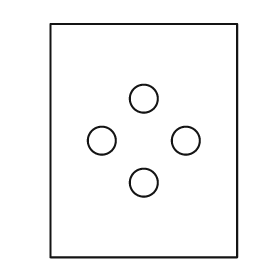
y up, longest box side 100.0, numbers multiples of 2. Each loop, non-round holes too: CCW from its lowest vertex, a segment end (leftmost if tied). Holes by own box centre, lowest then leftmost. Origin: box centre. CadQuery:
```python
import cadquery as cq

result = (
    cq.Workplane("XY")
    .moveTo(-40.0, -50.0)
    .lineTo(40.0, -50.0)
    .lineTo(40.0, 50.0)
    .lineTo(-40.0, 50.0)
    .close()
    .moveTo(0.0, -18.0)
    .circle(6.0)
    .moveTo(-18.0, 0.0)
    .circle(6.0)
    .moveTo(18.0, 0.0)
    .circle(6.0)
    .moveTo(0.0, 18.0)
    .circle(6.0)
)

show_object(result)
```